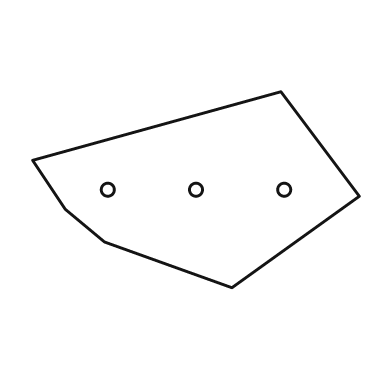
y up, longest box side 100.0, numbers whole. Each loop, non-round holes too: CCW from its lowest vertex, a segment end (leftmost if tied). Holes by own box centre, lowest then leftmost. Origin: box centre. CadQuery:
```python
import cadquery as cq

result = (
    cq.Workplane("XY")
    .moveTo(11.0, -30.0)
    .lineTo(50.0, -2.0)
    .lineTo(26.0, 30.0)
    .lineTo(-50.0, 9.0)
    .lineTo(-40.0, -6.0)
    .lineTo(-28.0, -16.0)
    .close()
    .moveTo(-27.0, 0.0)
    .circle(2.0)
    .moveTo(0.0, 0.0)
    .circle(2.0)
    .moveTo(27.0, 0.0)
    .circle(2.0)
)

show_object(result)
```